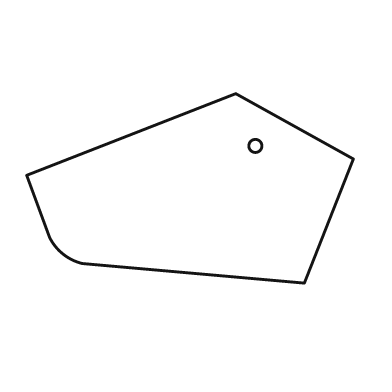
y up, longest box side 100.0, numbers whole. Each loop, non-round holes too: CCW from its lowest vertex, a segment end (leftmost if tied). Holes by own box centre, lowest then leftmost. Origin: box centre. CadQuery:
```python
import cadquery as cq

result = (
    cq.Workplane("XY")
    .moveTo(35.0, -29.0)
    .lineTo(50.0, 9.0)
    .lineTo(14.0, 29.0)
    .lineTo(-50.0, 4.0)
    .lineTo(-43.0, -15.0)
    .threePointArc((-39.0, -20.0), (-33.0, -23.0))
    .close()
    .moveTo(20.0, 13.0)
    .circle(2.0)
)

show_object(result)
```